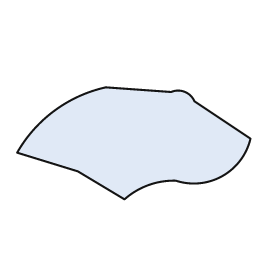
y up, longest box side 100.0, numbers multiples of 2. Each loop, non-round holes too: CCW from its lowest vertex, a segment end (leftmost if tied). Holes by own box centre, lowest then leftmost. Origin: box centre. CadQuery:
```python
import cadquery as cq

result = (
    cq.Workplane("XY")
    .moveTo(-4.0, -24.0)
    .threePointArc((6.0, -18.0), (18.0, -16.0))
    .threePointArc((38.0, -14.0), (50.0, 2.0))
    .lineTo(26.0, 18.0)
    .threePointArc((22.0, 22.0), (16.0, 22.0))
    .lineTo(-12.0, 24.0)
    .threePointArc((-34.0, 14.0), (-50.0, -4.0))
    .lineTo(-24.0, -12.0)
    .close()
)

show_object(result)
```